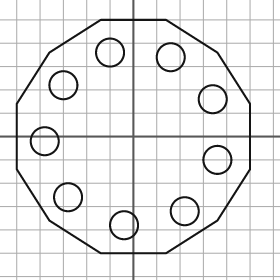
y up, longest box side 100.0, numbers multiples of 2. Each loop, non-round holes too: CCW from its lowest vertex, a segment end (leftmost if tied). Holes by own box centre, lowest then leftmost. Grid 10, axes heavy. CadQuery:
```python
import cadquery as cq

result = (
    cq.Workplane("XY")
    .moveTo(-14.0, -50.0)
    .lineTo(14.0, -50.0)
    .lineTo(36.0, -36.0)
    .lineTo(50.0, -14.0)
    .lineTo(50.0, 14.0)
    .lineTo(36.0, 36.0)
    .lineTo(14.0, 50.0)
    .lineTo(-14.0, 50.0)
    .lineTo(-36.0, 36.0)
    .lineTo(-50.0, 14.0)
    .lineTo(-50.0, -14.0)
    .lineTo(-36.0, -36.0)
    .close()
    .moveTo(-4.0, -38.0)
    .circle(6.0)
    .moveTo(22.0, -32.0)
    .circle(6.0)
    .moveTo(-28.0, -26.0)
    .circle(6.0)
    .moveTo(36.0, -10.0)
    .circle(6.0)
    .moveTo(-38.0, -2.0)
    .circle(6.0)
    .moveTo(34.0, 16.0)
    .circle(6.0)
    .moveTo(-30.0, 22.0)
    .circle(6.0)
    .moveTo(16.0, 34.0)
    .circle(6.0)
    .moveTo(-10.0, 36.0)
    .circle(6.0)
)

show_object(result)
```